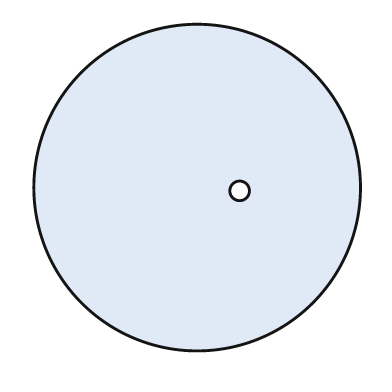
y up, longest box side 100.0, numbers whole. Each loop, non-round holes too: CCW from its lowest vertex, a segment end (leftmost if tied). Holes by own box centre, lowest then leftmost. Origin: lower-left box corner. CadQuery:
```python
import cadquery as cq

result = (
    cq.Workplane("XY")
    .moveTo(50.0, 50.0)
    .circle(50.0)
    .moveTo(63.0, 49.0)
    .circle(3.0)
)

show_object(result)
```